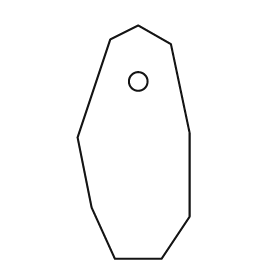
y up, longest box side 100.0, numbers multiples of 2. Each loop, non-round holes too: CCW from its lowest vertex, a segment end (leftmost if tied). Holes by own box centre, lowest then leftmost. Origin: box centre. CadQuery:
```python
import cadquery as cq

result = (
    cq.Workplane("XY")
    .moveTo(-8.0, -50.0)
    .lineTo(12.0, -50.0)
    .lineTo(24.0, -32.0)
    .lineTo(24.0, 4.0)
    .lineTo(16.0, 42.0)
    .lineTo(2.0, 50.0)
    .lineTo(-10.0, 44.0)
    .lineTo(-24.0, 2.0)
    .lineTo(-18.0, -28.0)
    .close()
    .moveTo(2.0, 26.0)
    .circle(4.0)
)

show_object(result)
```